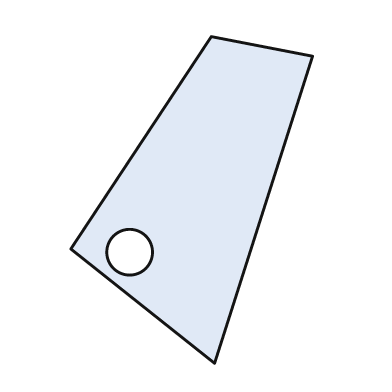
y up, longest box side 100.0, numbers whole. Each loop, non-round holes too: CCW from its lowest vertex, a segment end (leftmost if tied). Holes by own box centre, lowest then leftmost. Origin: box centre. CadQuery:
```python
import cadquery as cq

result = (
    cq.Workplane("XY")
    .moveTo(7.0, -50.0)
    .lineTo(37.0, 44.0)
    .lineTo(6.0, 50.0)
    .lineTo(-37.0, -15.0)
    .close()
    .moveTo(-19.0, -16.0)
    .circle(7.0)
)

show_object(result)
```